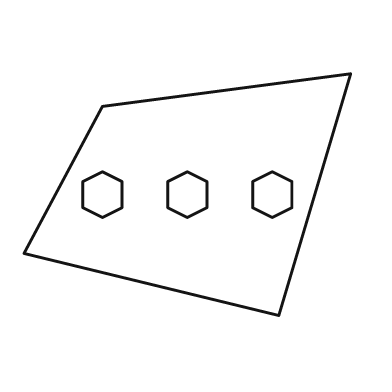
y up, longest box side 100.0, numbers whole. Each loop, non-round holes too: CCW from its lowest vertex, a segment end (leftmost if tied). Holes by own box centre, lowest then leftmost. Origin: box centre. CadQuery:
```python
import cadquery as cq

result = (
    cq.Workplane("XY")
    .moveTo(28.0, -37.0)
    .lineTo(50.0, 37.0)
    .lineTo(-26.0, 27.0)
    .lineTo(-50.0, -18.0)
    .close()
    .moveTo(-26.0, -7.0)
    .lineTo(-20.0, -4.0)
    .lineTo(-20.0, 4.0)
    .lineTo(-26.0, 7.0)
    .lineTo(-32.0, 4.0)
    .lineTo(-32.0, -4.0)
    .close()
    .moveTo(0.0, -7.0)
    .lineTo(6.0, -4.0)
    .lineTo(6.0, 4.0)
    .lineTo(0.0, 7.0)
    .lineTo(-6.0, 4.0)
    .lineTo(-6.0, -4.0)
    .close()
    .moveTo(26.0, -7.0)
    .lineTo(32.0, -4.0)
    .lineTo(32.0, 4.0)
    .lineTo(26.0, 7.0)
    .lineTo(20.0, 4.0)
    .lineTo(20.0, -4.0)
    .close()
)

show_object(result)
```